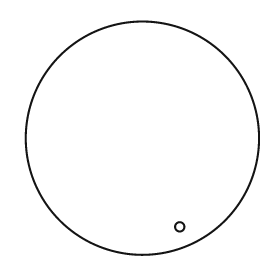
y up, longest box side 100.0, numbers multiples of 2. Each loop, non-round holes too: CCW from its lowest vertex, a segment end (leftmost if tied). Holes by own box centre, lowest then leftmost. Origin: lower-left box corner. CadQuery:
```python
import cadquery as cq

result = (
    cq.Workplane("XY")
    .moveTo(50.0, 50.0)
    .circle(50.0)
    .moveTo(66.0, 12.0)
    .circle(2.0)
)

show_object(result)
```